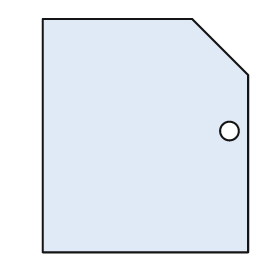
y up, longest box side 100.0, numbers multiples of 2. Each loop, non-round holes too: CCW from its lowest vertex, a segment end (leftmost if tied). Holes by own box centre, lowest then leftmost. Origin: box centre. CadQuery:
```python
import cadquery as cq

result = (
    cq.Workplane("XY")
    .moveTo(-44.0, -50.0)
    .lineTo(44.0, -50.0)
    .lineTo(44.0, 26.0)
    .lineTo(20.0, 50.0)
    .lineTo(-44.0, 50.0)
    .close()
    .moveTo(36.0, 2.0)
    .circle(4.0)
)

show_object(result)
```